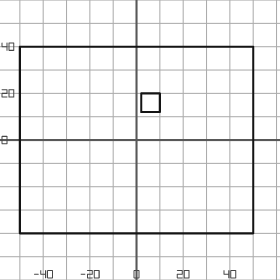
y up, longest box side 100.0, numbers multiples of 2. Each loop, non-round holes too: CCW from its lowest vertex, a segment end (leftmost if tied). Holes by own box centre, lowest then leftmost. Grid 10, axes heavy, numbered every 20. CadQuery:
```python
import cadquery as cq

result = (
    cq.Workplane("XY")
    .moveTo(-50.0, -40.0)
    .lineTo(50.0, -40.0)
    .lineTo(50.0, 40.0)
    .lineTo(-50.0, 40.0)
    .close()
    .moveTo(2.0, 12.0)
    .lineTo(10.0, 12.0)
    .lineTo(10.0, 20.0)
    .lineTo(2.0, 20.0)
    .close()
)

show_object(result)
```